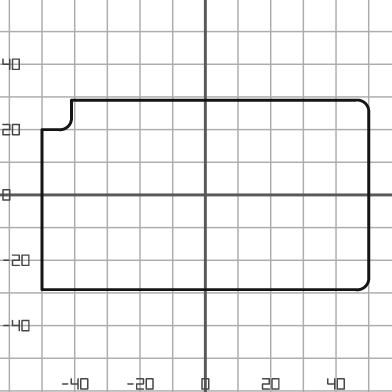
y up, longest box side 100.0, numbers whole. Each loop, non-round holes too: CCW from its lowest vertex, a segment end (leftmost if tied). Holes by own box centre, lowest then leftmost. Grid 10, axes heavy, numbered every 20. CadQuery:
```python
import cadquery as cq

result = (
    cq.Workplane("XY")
    .moveTo(-50.0, -29.0)
    .lineTo(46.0, -29.0)
    .threePointArc((49.0, -28.0), (50.0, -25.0))
    .lineTo(50.0, 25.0)
    .threePointArc((49.0, 28.0), (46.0, 29.0))
    .lineTo(-41.0, 29.0)
    .lineTo(-41.0, 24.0)
    .threePointArc((-42.0, 21.0), (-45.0, 20.0))
    .lineTo(-50.0, 20.0)
    .close()
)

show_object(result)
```